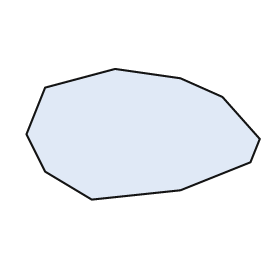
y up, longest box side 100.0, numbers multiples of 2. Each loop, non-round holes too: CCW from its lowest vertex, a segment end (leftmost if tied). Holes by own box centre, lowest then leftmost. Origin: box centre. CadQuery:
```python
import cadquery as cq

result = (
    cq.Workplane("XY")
    .moveTo(-22.0, -28.0)
    .lineTo(16.0, -24.0)
    .lineTo(46.0, -12.0)
    .lineTo(50.0, -2.0)
    .lineTo(34.0, 16.0)
    .lineTo(16.0, 24.0)
    .lineTo(-12.0, 28.0)
    .lineTo(-42.0, 20.0)
    .lineTo(-50.0, 0.0)
    .lineTo(-42.0, -16.0)
    .close()
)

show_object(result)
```